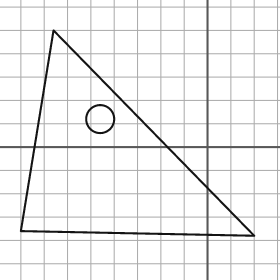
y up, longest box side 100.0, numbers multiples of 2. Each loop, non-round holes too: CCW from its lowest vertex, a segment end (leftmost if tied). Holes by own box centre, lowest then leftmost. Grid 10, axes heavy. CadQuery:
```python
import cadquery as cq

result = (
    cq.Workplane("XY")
    .moveTo(20.0, -38.0)
    .lineTo(-66.0, 50.0)
    .lineTo(-80.0, -36.0)
    .close()
    .moveTo(-46.0, 12.0)
    .circle(6.0)
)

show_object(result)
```